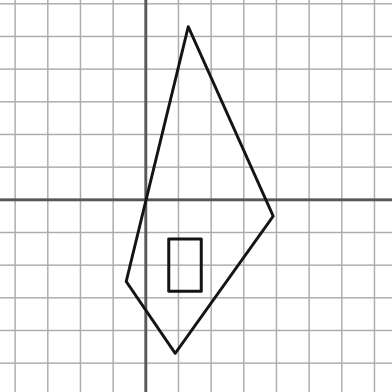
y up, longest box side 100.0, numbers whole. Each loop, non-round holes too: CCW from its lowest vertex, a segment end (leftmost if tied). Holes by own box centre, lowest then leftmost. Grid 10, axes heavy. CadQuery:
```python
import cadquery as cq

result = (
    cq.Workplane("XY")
    .moveTo(9.0, -47.0)
    .lineTo(39.0, -5.0)
    .lineTo(13.0, 53.0)
    .lineTo(-6.0, -25.0)
    .close()
    .moveTo(7.0, -28.0)
    .lineTo(17.0, -28.0)
    .lineTo(17.0, -12.0)
    .lineTo(7.0, -12.0)
    .close()
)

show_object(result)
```